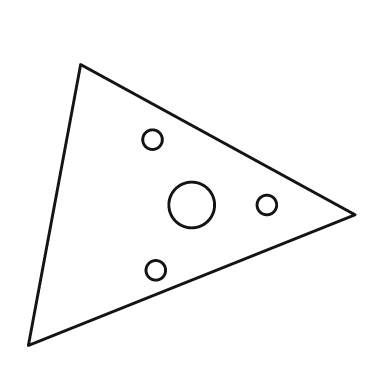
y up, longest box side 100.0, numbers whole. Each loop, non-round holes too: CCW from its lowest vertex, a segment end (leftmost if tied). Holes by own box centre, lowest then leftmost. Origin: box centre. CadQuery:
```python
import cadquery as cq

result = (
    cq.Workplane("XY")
    .moveTo(-50.0, -43.0)
    .lineTo(50.0, -3.0)
    .lineTo(-34.0, 43.0)
    .close()
    .moveTo(-11.0, -20.0)
    .circle(3.0)
    .moveTo(0.0, 0.0)
    .circle(7.0)
    .moveTo(23.0, 0.0)
    .circle(3.0)
    .moveTo(-12.0, 20.0)
    .circle(3.0)
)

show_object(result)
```